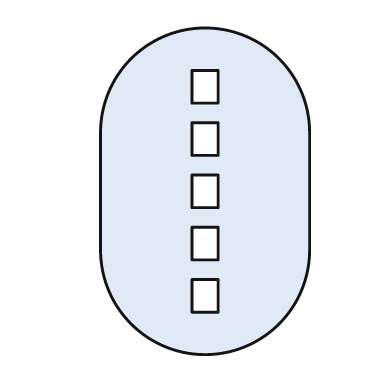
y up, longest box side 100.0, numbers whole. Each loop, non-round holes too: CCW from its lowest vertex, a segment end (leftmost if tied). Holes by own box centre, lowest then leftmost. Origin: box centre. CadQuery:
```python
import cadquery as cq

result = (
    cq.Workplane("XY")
    .moveTo(-32.0, -18.0)
    .threePointArc((0.0, -50.0), (32.0, -18.0))
    .lineTo(32.0, 18.0)
    .threePointArc((0.0, 50.0), (-32.0, 18.0))
    .close()
    .moveTo(-4.0, -37.0)
    .lineTo(4.0, -37.0)
    .lineTo(4.0, -27.0)
    .lineTo(-4.0, -27.0)
    .close()
    .moveTo(-4.0, -21.0)
    .lineTo(4.0, -21.0)
    .lineTo(4.0, -11.0)
    .lineTo(-4.0, -11.0)
    .close()
    .moveTo(-4.0, -5.0)
    .lineTo(4.0, -5.0)
    .lineTo(4.0, 5.0)
    .lineTo(-4.0, 5.0)
    .close()
    .moveTo(-4.0, 11.0)
    .lineTo(4.0, 11.0)
    .lineTo(4.0, 21.0)
    .lineTo(-4.0, 21.0)
    .close()
    .moveTo(-4.0, 27.0)
    .lineTo(4.0, 27.0)
    .lineTo(4.0, 37.0)
    .lineTo(-4.0, 37.0)
    .close()
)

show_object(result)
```